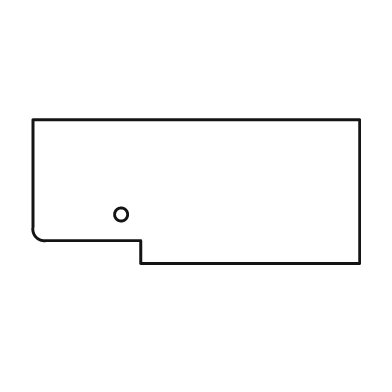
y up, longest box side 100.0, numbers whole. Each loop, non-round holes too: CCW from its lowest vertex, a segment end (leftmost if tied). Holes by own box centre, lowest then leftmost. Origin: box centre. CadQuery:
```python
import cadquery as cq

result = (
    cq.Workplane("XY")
    .moveTo(-17.0, -22.0)
    .lineTo(50.0, -22.0)
    .lineTo(50.0, 22.0)
    .lineTo(-50.0, 22.0)
    .lineTo(-50.0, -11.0)
    .threePointArc((-49.0, -14.0), (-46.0, -15.0))
    .lineTo(-17.0, -15.0)
    .close()
    .moveTo(-23.0, -7.0)
    .circle(2.0)
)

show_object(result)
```